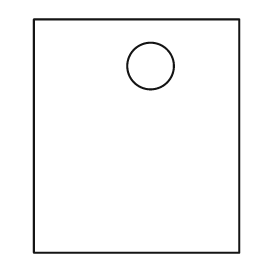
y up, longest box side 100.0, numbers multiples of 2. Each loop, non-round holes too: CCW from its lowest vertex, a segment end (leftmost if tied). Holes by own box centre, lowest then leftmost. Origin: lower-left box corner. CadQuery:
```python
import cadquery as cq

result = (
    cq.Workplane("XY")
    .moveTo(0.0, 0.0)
    .lineTo(88.0, 0.0)
    .lineTo(88.0, 100.0)
    .lineTo(0.0, 100.0)
    .close()
    .moveTo(50.0, 80.0)
    .circle(10.0)
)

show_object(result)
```